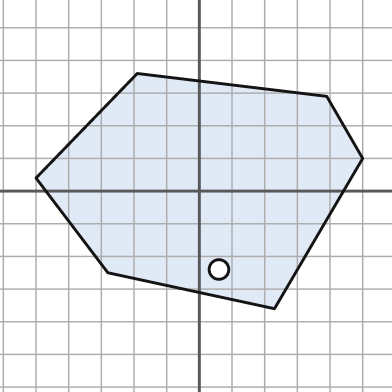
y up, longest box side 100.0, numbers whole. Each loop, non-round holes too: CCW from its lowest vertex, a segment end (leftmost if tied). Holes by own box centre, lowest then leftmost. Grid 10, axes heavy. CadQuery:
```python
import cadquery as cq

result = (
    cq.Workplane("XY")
    .moveTo(23.0, -36.0)
    .lineTo(50.0, 10.0)
    .lineTo(39.0, 29.0)
    .lineTo(-19.0, 36.0)
    .lineTo(-50.0, 4.0)
    .lineTo(-28.0, -25.0)
    .close()
    .moveTo(6.0, -24.0)
    .circle(3.0)
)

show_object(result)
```